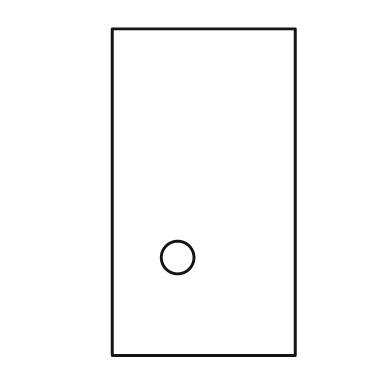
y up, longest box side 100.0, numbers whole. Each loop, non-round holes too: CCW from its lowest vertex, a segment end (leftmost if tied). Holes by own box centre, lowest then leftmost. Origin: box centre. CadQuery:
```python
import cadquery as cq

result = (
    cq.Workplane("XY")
    .moveTo(-28.0, -50.0)
    .lineTo(28.0, -50.0)
    .lineTo(28.0, 50.0)
    .lineTo(-28.0, 50.0)
    .close()
    .moveTo(-8.0, -20.0)
    .circle(5.0)
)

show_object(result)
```